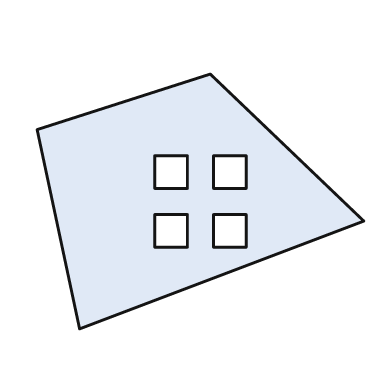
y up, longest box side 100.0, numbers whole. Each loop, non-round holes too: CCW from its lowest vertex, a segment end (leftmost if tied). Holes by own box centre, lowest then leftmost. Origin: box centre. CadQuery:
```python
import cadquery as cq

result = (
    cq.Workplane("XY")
    .moveTo(-37.0, -39.0)
    .lineTo(50.0, -6.0)
    .lineTo(3.0, 39.0)
    .lineTo(-50.0, 22.0)
    .close()
    .moveTo(-14.0, -14.0)
    .lineTo(-4.0, -14.0)
    .lineTo(-4.0, -4.0)
    .lineTo(-14.0, -4.0)
    .close()
    .moveTo(4.0, -14.0)
    .lineTo(14.0, -14.0)
    .lineTo(14.0, -4.0)
    .lineTo(4.0, -4.0)
    .close()
    .moveTo(-14.0, 4.0)
    .lineTo(-4.0, 4.0)
    .lineTo(-4.0, 14.0)
    .lineTo(-14.0, 14.0)
    .close()
    .moveTo(4.0, 4.0)
    .lineTo(14.0, 4.0)
    .lineTo(14.0, 14.0)
    .lineTo(4.0, 14.0)
    .close()
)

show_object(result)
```